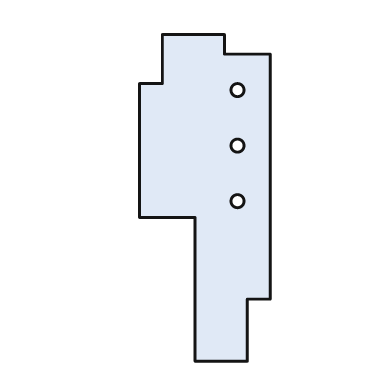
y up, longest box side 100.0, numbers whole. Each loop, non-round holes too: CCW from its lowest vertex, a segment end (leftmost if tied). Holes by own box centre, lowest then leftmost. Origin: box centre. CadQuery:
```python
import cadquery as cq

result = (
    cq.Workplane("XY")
    .moveTo(-3.0, -50.0)
    .lineTo(13.0, -50.0)
    .lineTo(13.0, -31.0)
    .lineTo(20.0, -31.0)
    .lineTo(20.0, 44.0)
    .lineTo(6.0, 44.0)
    .lineTo(6.0, 50.0)
    .lineTo(-13.0, 50.0)
    .lineTo(-13.0, 35.0)
    .lineTo(-20.0, 35.0)
    .lineTo(-20.0, -6.0)
    .lineTo(-3.0, -6.0)
    .close()
    .moveTo(10.0, -1.0)
    .circle(2.0)
    .moveTo(10.0, 16.0)
    .circle(2.0)
    .moveTo(10.0, 33.0)
    .circle(2.0)
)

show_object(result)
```